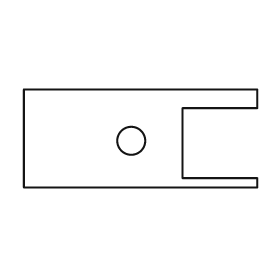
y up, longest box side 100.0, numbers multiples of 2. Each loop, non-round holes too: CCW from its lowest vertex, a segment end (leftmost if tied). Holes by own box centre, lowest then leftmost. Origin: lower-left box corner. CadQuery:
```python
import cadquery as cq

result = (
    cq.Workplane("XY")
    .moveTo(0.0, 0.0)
    .lineTo(100.0, 0.0)
    .lineTo(100.0, 4.0)
    .lineTo(68.0, 4.0)
    .lineTo(68.0, 34.0)
    .lineTo(100.0, 34.0)
    .lineTo(100.0, 42.0)
    .lineTo(0.0, 42.0)
    .close()
    .moveTo(46.0, 20.0)
    .circle(6.0)
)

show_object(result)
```